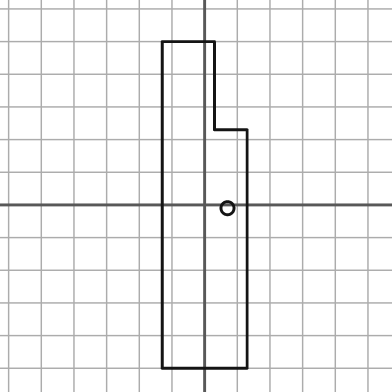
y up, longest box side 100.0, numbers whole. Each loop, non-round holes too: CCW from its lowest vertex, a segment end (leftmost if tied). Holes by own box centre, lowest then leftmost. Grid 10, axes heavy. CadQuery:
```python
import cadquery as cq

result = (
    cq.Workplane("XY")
    .moveTo(-13.0, -50.0)
    .lineTo(13.0, -50.0)
    .lineTo(13.0, 23.0)
    .lineTo(3.0, 23.0)
    .lineTo(3.0, 50.0)
    .lineTo(-13.0, 50.0)
    .close()
    .moveTo(7.0, -1.0)
    .circle(2.0)
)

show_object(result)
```